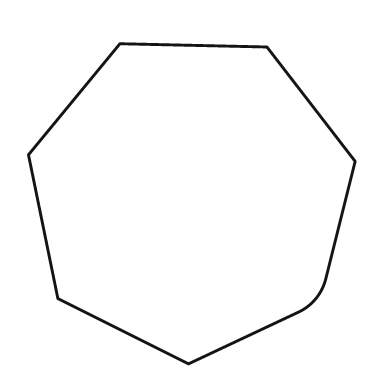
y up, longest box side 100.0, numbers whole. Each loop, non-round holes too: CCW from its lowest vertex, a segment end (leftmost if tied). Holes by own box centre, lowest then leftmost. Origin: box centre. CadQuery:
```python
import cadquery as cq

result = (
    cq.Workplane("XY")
    .moveTo(-1.0, -49.0)
    .lineTo(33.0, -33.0)
    .threePointArc((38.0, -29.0), (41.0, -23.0))
    .lineTo(50.0, 13.0)
    .lineTo(23.0, 48.0)
    .lineTo(-22.0, 49.0)
    .lineTo(-50.0, 15.0)
    .lineTo(-41.0, -29.0)
    .close()
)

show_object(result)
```